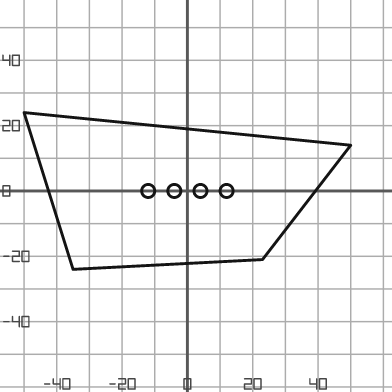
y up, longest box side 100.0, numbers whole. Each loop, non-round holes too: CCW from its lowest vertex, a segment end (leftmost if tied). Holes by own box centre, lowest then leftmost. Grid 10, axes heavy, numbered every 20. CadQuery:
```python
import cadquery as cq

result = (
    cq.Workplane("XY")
    .moveTo(-35.0, -24.0)
    .lineTo(23.0, -21.0)
    .lineTo(50.0, 14.0)
    .lineTo(-50.0, 24.0)
    .close()
    .moveTo(-12.0, 0.0)
    .circle(2.0)
    .moveTo(-4.0, 0.0)
    .circle(2.0)
    .moveTo(4.0, 0.0)
    .circle(2.0)
    .moveTo(12.0, 0.0)
    .circle(2.0)
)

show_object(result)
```